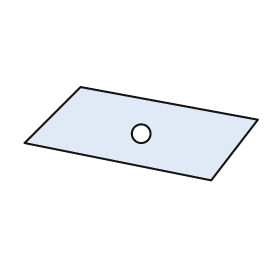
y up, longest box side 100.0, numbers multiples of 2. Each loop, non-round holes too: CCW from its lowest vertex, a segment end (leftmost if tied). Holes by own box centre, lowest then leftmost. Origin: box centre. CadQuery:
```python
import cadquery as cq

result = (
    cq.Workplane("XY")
    .moveTo(30.0, -20.0)
    .lineTo(50.0, 6.0)
    .lineTo(-26.0, 20.0)
    .lineTo(-50.0, -4.0)
    .close()
    .moveTo(0.0, 0.0)
    .circle(4.0)
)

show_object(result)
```